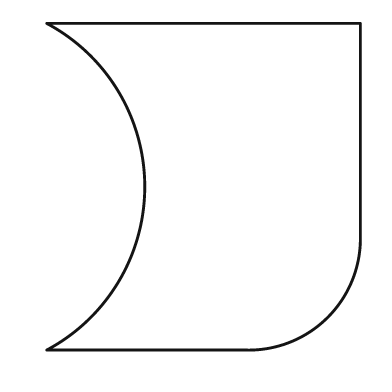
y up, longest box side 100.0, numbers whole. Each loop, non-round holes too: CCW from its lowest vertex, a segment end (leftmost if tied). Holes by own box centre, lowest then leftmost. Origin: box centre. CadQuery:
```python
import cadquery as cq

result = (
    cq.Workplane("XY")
    .moveTo(-48.0, -50.0)
    .lineTo(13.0, -50.0)
    .threePointArc((38.0, -40.0), (48.0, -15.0))
    .lineTo(48.0, 50.0)
    .lineTo(-48.0, 50.0)
    .threePointArc((-18.0, 0.0), (-48.0, -50.0))
    .close()
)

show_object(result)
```